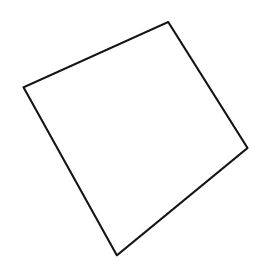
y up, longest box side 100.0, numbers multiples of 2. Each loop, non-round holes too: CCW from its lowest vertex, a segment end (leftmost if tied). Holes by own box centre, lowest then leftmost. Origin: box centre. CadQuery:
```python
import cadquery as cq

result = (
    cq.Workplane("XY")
    .moveTo(-8.0, -50.0)
    .lineTo(48.0, -4.0)
    .lineTo(14.0, 50.0)
    .lineTo(-48.0, 22.0)
    .close()
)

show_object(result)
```